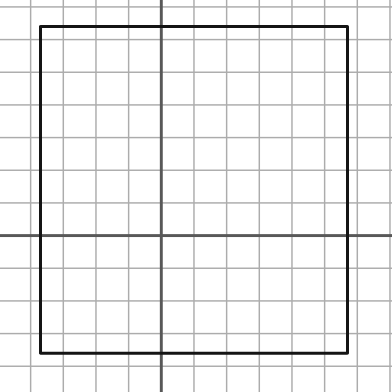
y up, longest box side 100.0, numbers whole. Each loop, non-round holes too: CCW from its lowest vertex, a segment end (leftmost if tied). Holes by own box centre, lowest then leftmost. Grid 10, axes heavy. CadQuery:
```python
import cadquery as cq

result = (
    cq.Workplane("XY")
    .moveTo(-37.0, -36.0)
    .lineTo(57.0, -36.0)
    .lineTo(57.0, 64.0)
    .lineTo(-37.0, 64.0)
    .close()
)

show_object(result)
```